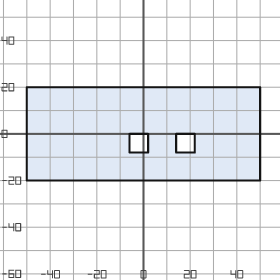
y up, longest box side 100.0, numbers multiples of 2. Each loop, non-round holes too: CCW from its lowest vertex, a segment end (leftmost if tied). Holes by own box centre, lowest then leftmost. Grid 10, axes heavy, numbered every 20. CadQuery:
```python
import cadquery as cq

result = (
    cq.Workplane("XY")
    .moveTo(-50.0, -20.0)
    .lineTo(50.0, -20.0)
    .lineTo(50.0, 20.0)
    .lineTo(-50.0, 20.0)
    .close()
    .moveTo(-6.0, -8.0)
    .lineTo(2.0, -8.0)
    .lineTo(2.0, 0.0)
    .lineTo(-6.0, 0.0)
    .close()
    .moveTo(14.0, -8.0)
    .lineTo(22.0, -8.0)
    .lineTo(22.0, 0.0)
    .lineTo(14.0, 0.0)
    .close()
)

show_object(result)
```